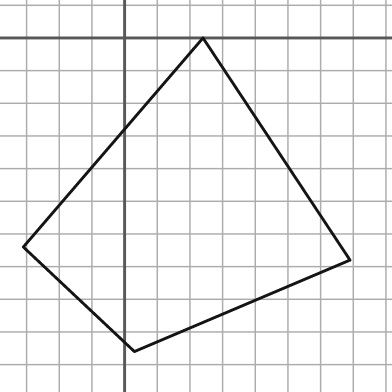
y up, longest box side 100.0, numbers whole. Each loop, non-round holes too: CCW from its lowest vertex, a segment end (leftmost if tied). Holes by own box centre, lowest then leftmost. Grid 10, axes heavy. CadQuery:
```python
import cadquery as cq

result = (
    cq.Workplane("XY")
    .moveTo(3.0, -96.0)
    .lineTo(69.0, -68.0)
    .lineTo(24.0, 0.0)
    .lineTo(-31.0, -64.0)
    .close()
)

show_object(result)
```